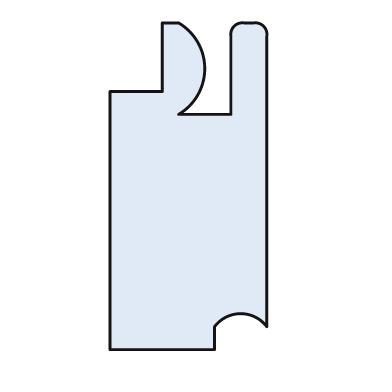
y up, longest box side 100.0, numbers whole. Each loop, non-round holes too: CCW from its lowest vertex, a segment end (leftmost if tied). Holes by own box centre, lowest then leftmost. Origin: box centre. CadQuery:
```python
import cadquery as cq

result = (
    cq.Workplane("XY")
    .moveTo(-24.0, -50.0)
    .lineTo(8.0, -50.0)
    .lineTo(8.0, -43.0)
    .threePointArc((16.0, -39.0), (24.0, -43.0))
    .lineTo(24.0, 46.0)
    .threePointArc((23.0, 49.0), (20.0, 50.0))
    .lineTo(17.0, 50.0)
    .threePointArc((14.0, 49.0), (13.0, 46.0))
    .lineTo(13.0, 22.0)
    .lineTo(-3.0, 22.0)
    .threePointArc((5.0, 36.0), (-3.0, 50.0))
    .lineTo(-8.0, 50.0)
    .lineTo(-8.0, 29.0)
    .lineTo(-24.0, 29.0)
    .close()
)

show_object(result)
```